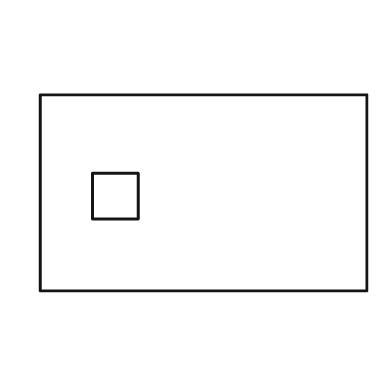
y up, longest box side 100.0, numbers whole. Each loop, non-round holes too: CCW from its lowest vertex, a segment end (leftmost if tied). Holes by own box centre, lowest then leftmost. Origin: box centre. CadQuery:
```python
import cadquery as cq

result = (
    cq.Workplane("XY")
    .moveTo(-50.0, -30.0)
    .lineTo(50.0, -30.0)
    .lineTo(50.0, 30.0)
    .lineTo(-50.0, 30.0)
    .close()
    .moveTo(-34.0, -8.0)
    .lineTo(-20.0, -8.0)
    .lineTo(-20.0, 6.0)
    .lineTo(-34.0, 6.0)
    .close()
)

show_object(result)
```